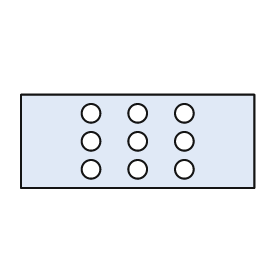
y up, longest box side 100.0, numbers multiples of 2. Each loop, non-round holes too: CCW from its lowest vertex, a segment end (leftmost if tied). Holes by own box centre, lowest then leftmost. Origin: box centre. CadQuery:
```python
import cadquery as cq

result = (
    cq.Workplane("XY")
    .moveTo(-50.0, -20.0)
    .lineTo(50.0, -20.0)
    .lineTo(50.0, 20.0)
    .lineTo(-50.0, 20.0)
    .close()
    .moveTo(-20.0, -12.0)
    .circle(4.0)
    .moveTo(0.0, -12.0)
    .circle(4.0)
    .moveTo(20.0, -12.0)
    .circle(4.0)
    .moveTo(-20.0, 0.0)
    .circle(4.0)
    .moveTo(0.0, 0.0)
    .circle(4.0)
    .moveTo(20.0, 0.0)
    .circle(4.0)
    .moveTo(-20.0, 12.0)
    .circle(4.0)
    .moveTo(0.0, 12.0)
    .circle(4.0)
    .moveTo(20.0, 12.0)
    .circle(4.0)
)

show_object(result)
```